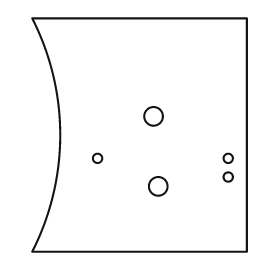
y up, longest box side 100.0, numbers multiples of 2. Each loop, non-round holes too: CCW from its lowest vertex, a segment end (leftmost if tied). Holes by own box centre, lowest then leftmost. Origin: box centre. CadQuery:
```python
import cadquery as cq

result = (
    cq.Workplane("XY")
    .moveTo(-46.0, -50.0)
    .lineTo(46.0, -50.0)
    .lineTo(46.0, 50.0)
    .lineTo(-46.0, 50.0)
    .threePointArc((-34.0, 0.0), (-46.0, -50.0))
    .close()
    .moveTo(8.0, -22.0)
    .circle(4.0)
    .moveTo(38.0, -18.0)
    .circle(2.0)
    .moveTo(-18.0, -10.0)
    .circle(2.0)
    .moveTo(38.0, -10.0)
    .circle(2.0)
    .moveTo(6.0, 8.0)
    .circle(4.0)
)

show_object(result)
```